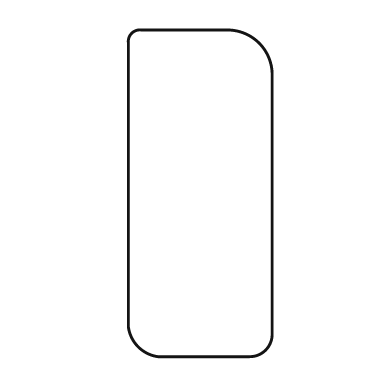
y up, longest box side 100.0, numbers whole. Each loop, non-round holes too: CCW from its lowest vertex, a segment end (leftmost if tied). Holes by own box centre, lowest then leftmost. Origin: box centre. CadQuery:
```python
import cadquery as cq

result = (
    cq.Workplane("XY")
    .moveTo(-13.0, -50.0)
    .lineTo(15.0, -50.0)
    .threePointArc((20.0, -48.0), (22.0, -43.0))
    .lineTo(22.0, 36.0)
    .threePointArc((18.0, 46.0), (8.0, 50.0))
    .lineTo(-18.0, 50.0)
    .threePointArc((-21.0, 49.0), (-22.0, 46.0))
    .lineTo(-22.0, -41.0)
    .threePointArc((-19.0, -47.0), (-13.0, -50.0))
    .close()
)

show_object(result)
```